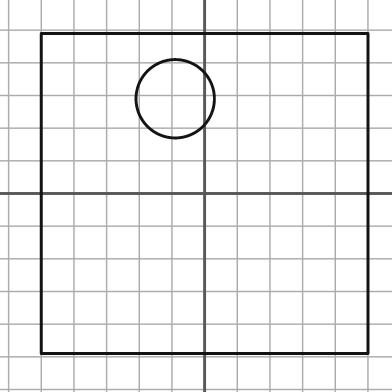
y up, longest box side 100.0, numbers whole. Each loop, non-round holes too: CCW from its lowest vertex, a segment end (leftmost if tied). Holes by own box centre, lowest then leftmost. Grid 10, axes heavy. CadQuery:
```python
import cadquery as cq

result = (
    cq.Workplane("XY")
    .moveTo(-50.0, -49.0)
    .lineTo(50.0, -49.0)
    .lineTo(50.0, 49.0)
    .lineTo(-50.0, 49.0)
    .close()
    .moveTo(-9.0, 29.0)
    .circle(12.0)
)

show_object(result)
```